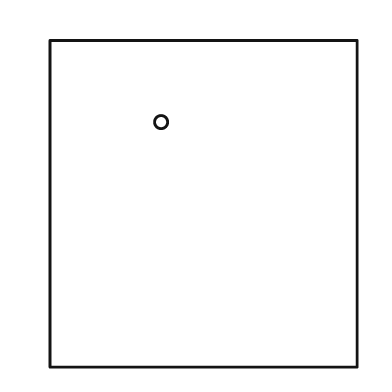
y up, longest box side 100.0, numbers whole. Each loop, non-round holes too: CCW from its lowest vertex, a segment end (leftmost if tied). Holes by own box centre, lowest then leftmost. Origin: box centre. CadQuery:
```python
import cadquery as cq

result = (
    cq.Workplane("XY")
    .moveTo(-47.0, -50.0)
    .lineTo(47.0, -50.0)
    .lineTo(47.0, 50.0)
    .lineTo(-47.0, 50.0)
    .close()
    .moveTo(-13.0, 25.0)
    .circle(2.0)
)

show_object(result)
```